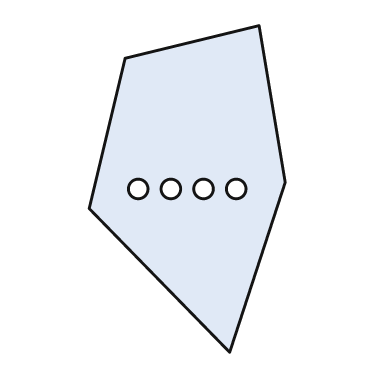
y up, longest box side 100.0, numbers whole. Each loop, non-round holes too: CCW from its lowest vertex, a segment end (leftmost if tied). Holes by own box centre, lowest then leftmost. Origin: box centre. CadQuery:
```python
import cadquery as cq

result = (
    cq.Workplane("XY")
    .moveTo(13.0, -50.0)
    .lineTo(30.0, 2.0)
    .lineTo(22.0, 50.0)
    .lineTo(-19.0, 40.0)
    .lineTo(-30.0, -6.0)
    .close()
    .moveTo(-15.0, 0.0)
    .circle(3.0)
    .moveTo(-5.0, 0.0)
    .circle(3.0)
    .moveTo(5.0, 0.0)
    .circle(3.0)
    .moveTo(15.0, 0.0)
    .circle(3.0)
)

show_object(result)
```